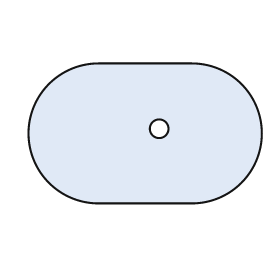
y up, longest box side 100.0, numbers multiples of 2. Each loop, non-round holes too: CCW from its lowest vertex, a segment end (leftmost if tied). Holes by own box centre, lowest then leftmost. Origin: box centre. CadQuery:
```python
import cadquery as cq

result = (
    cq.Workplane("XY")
    .moveTo(-20.0, -30.0)
    .lineTo(20.0, -30.0)
    .threePointArc((50.0, 0.0), (20.0, 30.0))
    .lineTo(-20.0, 30.0)
    .threePointArc((-50.0, 0.0), (-20.0, -30.0))
    .close()
    .moveTo(6.0, 2.0)
    .circle(4.0)
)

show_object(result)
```